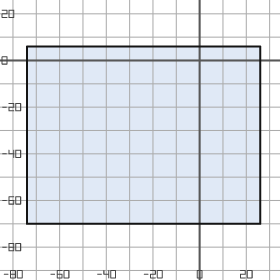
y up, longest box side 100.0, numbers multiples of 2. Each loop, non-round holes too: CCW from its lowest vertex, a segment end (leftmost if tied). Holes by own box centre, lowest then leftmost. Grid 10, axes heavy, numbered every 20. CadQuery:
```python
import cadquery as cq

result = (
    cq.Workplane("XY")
    .moveTo(-74.0, -70.0)
    .lineTo(26.0, -70.0)
    .lineTo(26.0, 6.0)
    .lineTo(-74.0, 6.0)
    .close()
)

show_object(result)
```